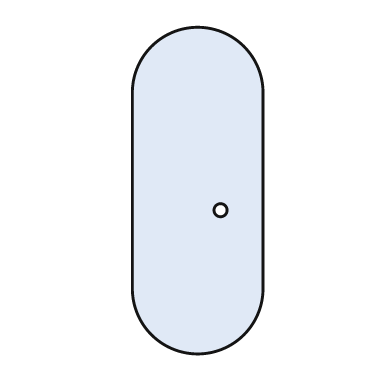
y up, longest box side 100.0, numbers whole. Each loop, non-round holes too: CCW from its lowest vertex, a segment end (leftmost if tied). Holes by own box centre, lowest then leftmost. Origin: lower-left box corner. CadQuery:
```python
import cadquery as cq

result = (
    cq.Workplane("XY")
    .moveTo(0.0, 20.0)
    .threePointArc((20.0, 0.0), (40.0, 20.0))
    .lineTo(40.0, 80.0)
    .threePointArc((20.0, 100.0), (0.0, 80.0))
    .close()
    .moveTo(27.0, 44.0)
    .circle(2.0)
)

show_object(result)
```